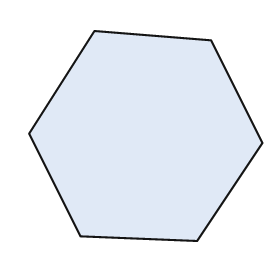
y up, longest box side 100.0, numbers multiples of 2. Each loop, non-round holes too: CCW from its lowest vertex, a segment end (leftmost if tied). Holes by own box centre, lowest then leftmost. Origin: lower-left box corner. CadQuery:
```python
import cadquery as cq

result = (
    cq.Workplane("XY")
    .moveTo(72.0, 0.0)
    .lineTo(100.0, 42.0)
    .lineTo(78.0, 86.0)
    .lineTo(28.0, 90.0)
    .lineTo(0.0, 46.0)
    .lineTo(22.0, 2.0)
    .close()
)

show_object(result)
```